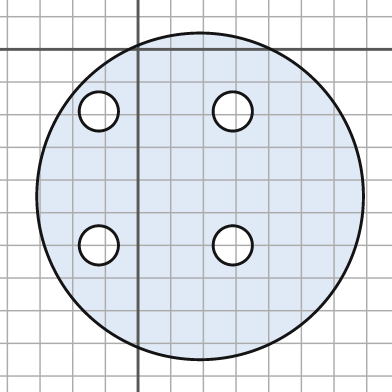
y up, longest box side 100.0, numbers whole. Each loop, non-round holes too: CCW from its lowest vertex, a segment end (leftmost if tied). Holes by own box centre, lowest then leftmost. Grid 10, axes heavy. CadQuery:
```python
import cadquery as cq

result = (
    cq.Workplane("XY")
    .moveTo(19.0, -45.0)
    .circle(50.0)
    .moveTo(-12.0, -60.0)
    .circle(6.0)
    .moveTo(29.0, -60.0)
    .circle(6.0)
    .moveTo(-12.0, -19.0)
    .circle(6.0)
    .moveTo(29.0, -19.0)
    .circle(6.0)
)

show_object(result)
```